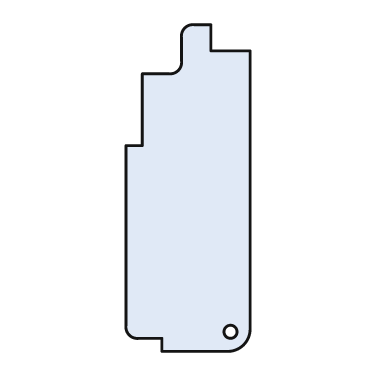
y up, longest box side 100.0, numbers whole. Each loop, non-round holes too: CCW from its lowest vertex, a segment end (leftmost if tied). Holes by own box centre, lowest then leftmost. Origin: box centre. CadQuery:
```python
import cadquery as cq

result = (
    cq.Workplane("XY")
    .moveTo(-8.0, -50.0)
    .lineTo(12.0, -50.0)
    .threePointArc((17.0, -48.0), (19.0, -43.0))
    .lineTo(19.0, 42.0)
    .lineTo(7.0, 42.0)
    .lineTo(7.0, 50.0)
    .lineTo(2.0, 50.0)
    .threePointArc((-1.0, 49.0), (-2.0, 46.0))
    .lineTo(-2.0, 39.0)
    .threePointArc((-3.0, 36.0), (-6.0, 35.0))
    .lineTo(-14.0, 35.0)
    .lineTo(-14.0, 13.0)
    .lineTo(-19.0, 13.0)
    .lineTo(-19.0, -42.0)
    .threePointArc((-18.0, -45.0), (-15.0, -46.0))
    .lineTo(-8.0, -46.0)
    .close()
    .moveTo(13.0, -44.0)
    .circle(2.0)
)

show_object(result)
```